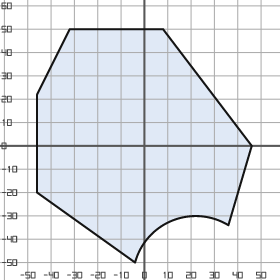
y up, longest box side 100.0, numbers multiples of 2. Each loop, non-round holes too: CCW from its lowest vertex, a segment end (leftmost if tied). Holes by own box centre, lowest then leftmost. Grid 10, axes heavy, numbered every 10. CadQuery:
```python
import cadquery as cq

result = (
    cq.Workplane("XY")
    .moveTo(-4.0, -50.0)
    .threePointArc((12.0, -32.0), (36.0, -34.0))
    .lineTo(46.0, 0.0)
    .lineTo(8.0, 50.0)
    .lineTo(-32.0, 50.0)
    .lineTo(-46.0, 22.0)
    .lineTo(-46.0, -20.0)
    .close()
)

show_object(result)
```